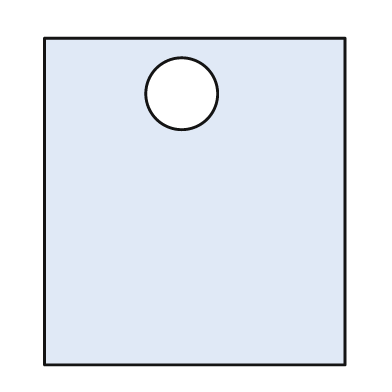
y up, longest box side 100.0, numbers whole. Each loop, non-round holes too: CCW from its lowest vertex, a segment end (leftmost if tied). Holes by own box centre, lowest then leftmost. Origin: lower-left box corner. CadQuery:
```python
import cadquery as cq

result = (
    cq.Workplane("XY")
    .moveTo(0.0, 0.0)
    .lineTo(92.0, 0.0)
    .lineTo(92.0, 100.0)
    .lineTo(0.0, 100.0)
    .close()
    .moveTo(42.0, 83.0)
    .circle(11.0)
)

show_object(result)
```